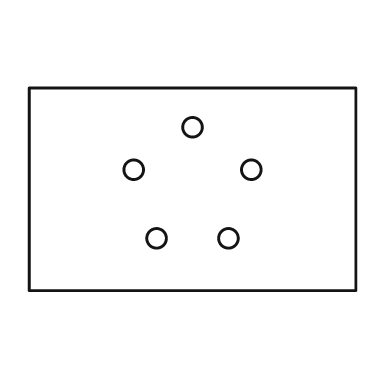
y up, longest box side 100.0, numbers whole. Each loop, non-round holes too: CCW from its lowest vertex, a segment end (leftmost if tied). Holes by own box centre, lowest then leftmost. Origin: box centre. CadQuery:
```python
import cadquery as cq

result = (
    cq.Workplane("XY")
    .moveTo(-50.0, -31.0)
    .lineTo(50.0, -31.0)
    .lineTo(50.0, 31.0)
    .lineTo(-50.0, 31.0)
    .close()
    .moveTo(-11.0, -15.0)
    .circle(3.0)
    .moveTo(11.0, -15.0)
    .circle(3.0)
    .moveTo(-18.0, 6.0)
    .circle(3.0)
    .moveTo(18.0, 6.0)
    .circle(3.0)
    .moveTo(0.0, 19.0)
    .circle(3.0)
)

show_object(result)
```